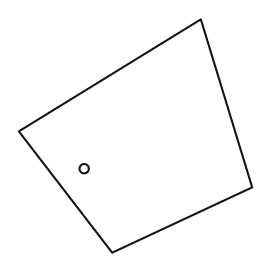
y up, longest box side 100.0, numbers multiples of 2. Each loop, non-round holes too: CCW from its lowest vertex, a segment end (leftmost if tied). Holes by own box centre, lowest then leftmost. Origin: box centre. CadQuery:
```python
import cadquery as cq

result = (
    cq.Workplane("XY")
    .moveTo(-10.0, -50.0)
    .lineTo(50.0, -22.0)
    .lineTo(28.0, 50.0)
    .lineTo(-50.0, 2.0)
    .close()
    .moveTo(-22.0, -14.0)
    .circle(2.0)
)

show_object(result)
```